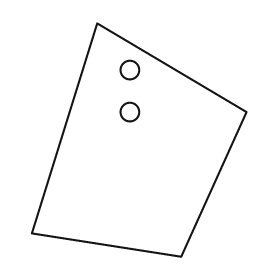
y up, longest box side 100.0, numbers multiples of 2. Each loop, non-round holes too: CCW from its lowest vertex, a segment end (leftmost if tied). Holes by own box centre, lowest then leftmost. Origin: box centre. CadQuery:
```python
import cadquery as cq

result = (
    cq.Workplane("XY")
    .moveTo(18.0, -50.0)
    .lineTo(46.0, 12.0)
    .lineTo(-18.0, 50.0)
    .lineTo(-46.0, -40.0)
    .close()
    .moveTo(-4.0, 12.0)
    .circle(4.0)
    .moveTo(-4.0, 30.0)
    .circle(4.0)
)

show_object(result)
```